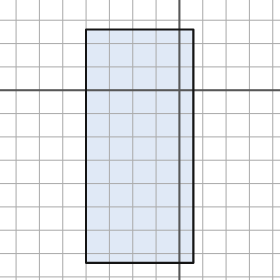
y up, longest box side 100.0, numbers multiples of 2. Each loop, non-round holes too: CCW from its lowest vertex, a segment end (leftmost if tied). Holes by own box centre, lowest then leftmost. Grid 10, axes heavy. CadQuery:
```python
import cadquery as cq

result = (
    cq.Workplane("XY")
    .moveTo(-40.0, -74.0)
    .lineTo(6.0, -74.0)
    .lineTo(6.0, 26.0)
    .lineTo(-40.0, 26.0)
    .close()
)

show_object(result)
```